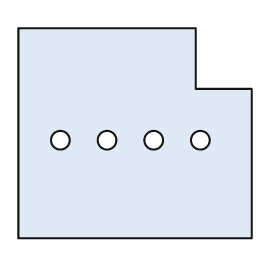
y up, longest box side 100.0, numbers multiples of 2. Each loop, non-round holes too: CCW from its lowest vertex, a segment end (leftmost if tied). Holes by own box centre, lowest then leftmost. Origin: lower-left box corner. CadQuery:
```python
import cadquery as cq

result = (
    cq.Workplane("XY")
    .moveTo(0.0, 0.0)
    .lineTo(100.0, 0.0)
    .lineTo(100.0, 64.0)
    .lineTo(76.0, 64.0)
    .lineTo(76.0, 90.0)
    .lineTo(0.0, 90.0)
    .close()
    .moveTo(18.0, 42.0)
    .circle(4.0)
    .moveTo(38.0, 42.0)
    .circle(4.0)
    .moveTo(58.0, 42.0)
    .circle(4.0)
    .moveTo(78.0, 42.0)
    .circle(4.0)
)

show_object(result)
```